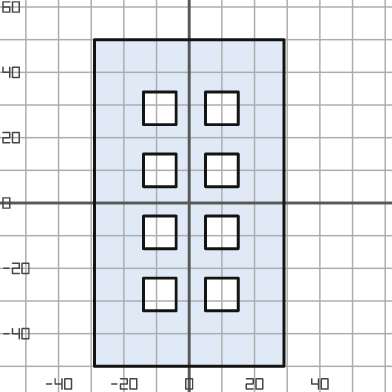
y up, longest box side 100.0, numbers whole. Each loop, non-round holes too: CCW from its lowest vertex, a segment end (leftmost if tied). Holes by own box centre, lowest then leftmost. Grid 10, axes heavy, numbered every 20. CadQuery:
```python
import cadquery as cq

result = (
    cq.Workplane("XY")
    .moveTo(-29.0, -50.0)
    .lineTo(29.0, -50.0)
    .lineTo(29.0, 50.0)
    .lineTo(-29.0, 50.0)
    .close()
    .moveTo(-14.0, -33.0)
    .lineTo(-4.0, -33.0)
    .lineTo(-4.0, -23.0)
    .lineTo(-14.0, -23.0)
    .close()
    .moveTo(5.0, -33.0)
    .lineTo(15.0, -33.0)
    .lineTo(15.0, -23.0)
    .lineTo(5.0, -23.0)
    .close()
    .moveTo(-14.0, -14.0)
    .lineTo(-4.0, -14.0)
    .lineTo(-4.0, -4.0)
    .lineTo(-14.0, -4.0)
    .close()
    .moveTo(5.0, -14.0)
    .lineTo(15.0, -14.0)
    .lineTo(15.0, -4.0)
    .lineTo(5.0, -4.0)
    .close()
    .moveTo(-14.0, 5.0)
    .lineTo(-4.0, 5.0)
    .lineTo(-4.0, 15.0)
    .lineTo(-14.0, 15.0)
    .close()
    .moveTo(5.0, 5.0)
    .lineTo(15.0, 5.0)
    .lineTo(15.0, 15.0)
    .lineTo(5.0, 15.0)
    .close()
    .moveTo(-14.0, 24.0)
    .lineTo(-4.0, 24.0)
    .lineTo(-4.0, 34.0)
    .lineTo(-14.0, 34.0)
    .close()
    .moveTo(5.0, 24.0)
    .lineTo(15.0, 24.0)
    .lineTo(15.0, 34.0)
    .lineTo(5.0, 34.0)
    .close()
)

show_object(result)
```